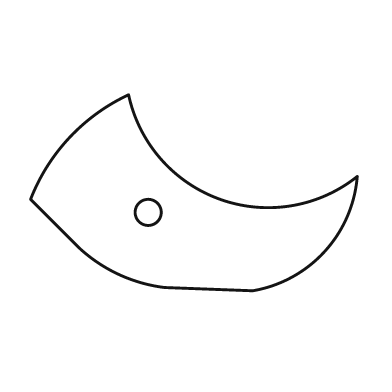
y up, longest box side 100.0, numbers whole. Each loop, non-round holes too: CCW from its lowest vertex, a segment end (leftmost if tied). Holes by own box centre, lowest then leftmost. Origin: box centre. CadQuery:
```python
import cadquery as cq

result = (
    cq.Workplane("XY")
    .moveTo(18.0, -30.0)
    .threePointArc((40.0, -18.0), (50.0, 5.0))
    .threePointArc((8.0, -2.0), (-20.0, 30.0))
    .threePointArc((-38.0, 17.0), (-50.0, -2.0))
    .lineTo(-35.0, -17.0)
    .threePointArc((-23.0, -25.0), (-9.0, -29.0))
    .close()
    .moveTo(-14.0, -6.0)
    .circle(4.0)
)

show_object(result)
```